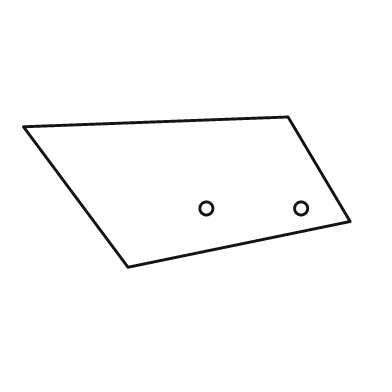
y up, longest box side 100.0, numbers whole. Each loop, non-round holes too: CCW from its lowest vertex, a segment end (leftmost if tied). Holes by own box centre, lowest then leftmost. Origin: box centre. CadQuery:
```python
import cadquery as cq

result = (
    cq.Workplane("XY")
    .moveTo(-18.0, -23.0)
    .lineTo(50.0, -9.0)
    .lineTo(31.0, 23.0)
    .lineTo(-50.0, 20.0)
    .close()
    .moveTo(6.0, -5.0)
    .circle(2.0)
    .moveTo(35.0, -5.0)
    .circle(2.0)
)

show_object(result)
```